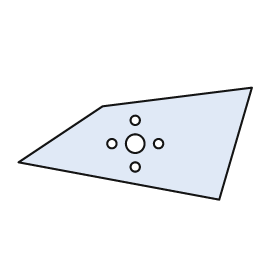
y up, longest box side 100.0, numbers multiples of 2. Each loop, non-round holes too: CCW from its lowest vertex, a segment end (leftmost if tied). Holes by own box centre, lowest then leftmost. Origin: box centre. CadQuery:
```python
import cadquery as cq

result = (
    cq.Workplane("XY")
    .moveTo(36.0, -24.0)
    .lineTo(50.0, 24.0)
    .lineTo(-14.0, 16.0)
    .lineTo(-50.0, -8.0)
    .close()
    .moveTo(0.0, -10.0)
    .circle(2.0)
    .moveTo(-10.0, 0.0)
    .circle(2.0)
    .moveTo(0.0, 0.0)
    .circle(4.0)
    .moveTo(10.0, 0.0)
    .circle(2.0)
    .moveTo(0.0, 10.0)
    .circle(2.0)
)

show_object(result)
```